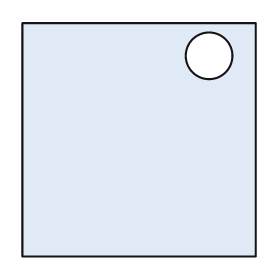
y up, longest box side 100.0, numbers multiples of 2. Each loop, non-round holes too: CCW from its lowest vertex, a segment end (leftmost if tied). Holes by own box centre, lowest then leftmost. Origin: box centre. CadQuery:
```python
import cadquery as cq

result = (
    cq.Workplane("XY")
    .moveTo(-50.0, -50.0)
    .lineTo(50.0, -50.0)
    .lineTo(50.0, 50.0)
    .lineTo(-50.0, 50.0)
    .close()
    .moveTo(30.0, 36.0)
    .circle(10.0)
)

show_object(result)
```